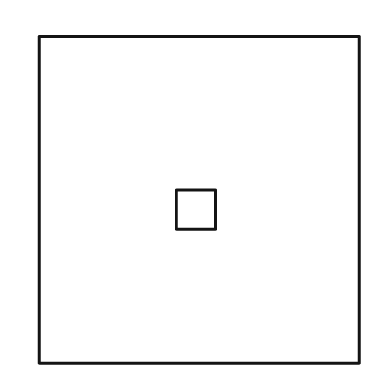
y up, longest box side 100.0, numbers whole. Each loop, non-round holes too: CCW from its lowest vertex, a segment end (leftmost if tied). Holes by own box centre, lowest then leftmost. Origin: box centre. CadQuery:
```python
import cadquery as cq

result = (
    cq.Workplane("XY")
    .moveTo(-49.0, -50.0)
    .lineTo(49.0, -50.0)
    .lineTo(49.0, 50.0)
    .lineTo(-49.0, 50.0)
    .close()
    .moveTo(-7.0, -9.0)
    .lineTo(5.0, -9.0)
    .lineTo(5.0, 3.0)
    .lineTo(-7.0, 3.0)
    .close()
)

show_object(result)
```